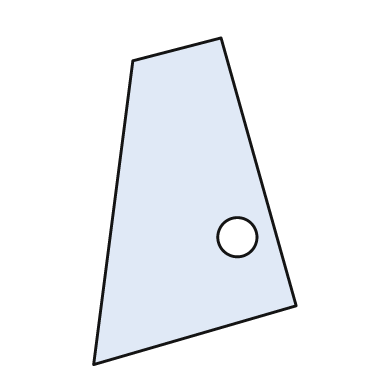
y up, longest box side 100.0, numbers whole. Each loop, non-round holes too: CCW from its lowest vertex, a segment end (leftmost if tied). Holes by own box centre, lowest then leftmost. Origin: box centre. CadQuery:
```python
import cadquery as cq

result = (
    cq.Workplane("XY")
    .moveTo(-31.0, -50.0)
    .lineTo(31.0, -32.0)
    .lineTo(8.0, 50.0)
    .lineTo(-19.0, 43.0)
    .close()
    .moveTo(13.0, -11.0)
    .circle(6.0)
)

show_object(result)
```